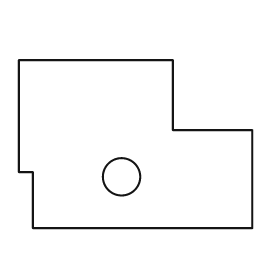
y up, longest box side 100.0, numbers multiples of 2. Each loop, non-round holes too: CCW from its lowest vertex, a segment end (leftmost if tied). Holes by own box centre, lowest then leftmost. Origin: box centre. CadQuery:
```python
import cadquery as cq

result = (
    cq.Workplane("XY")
    .moveTo(-44.0, -36.0)
    .lineTo(50.0, -36.0)
    .lineTo(50.0, 6.0)
    .lineTo(16.0, 6.0)
    .lineTo(16.0, 36.0)
    .lineTo(-50.0, 36.0)
    .lineTo(-50.0, -12.0)
    .lineTo(-44.0, -12.0)
    .close()
    .moveTo(-6.0, -14.0)
    .circle(8.0)
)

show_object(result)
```